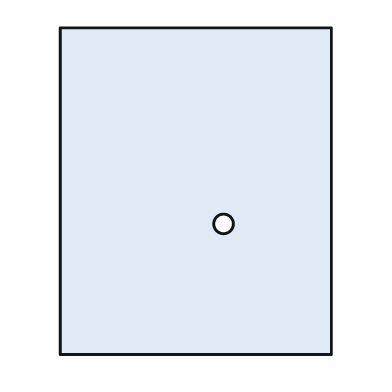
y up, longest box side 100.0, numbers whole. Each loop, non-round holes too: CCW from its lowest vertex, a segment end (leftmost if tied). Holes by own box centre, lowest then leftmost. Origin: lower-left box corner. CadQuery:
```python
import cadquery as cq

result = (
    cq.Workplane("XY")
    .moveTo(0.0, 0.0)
    .lineTo(83.0, 0.0)
    .lineTo(83.0, 100.0)
    .lineTo(0.0, 100.0)
    .close()
    .moveTo(50.0, 40.0)
    .circle(3.0)
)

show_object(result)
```